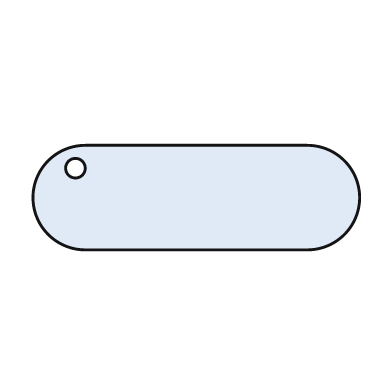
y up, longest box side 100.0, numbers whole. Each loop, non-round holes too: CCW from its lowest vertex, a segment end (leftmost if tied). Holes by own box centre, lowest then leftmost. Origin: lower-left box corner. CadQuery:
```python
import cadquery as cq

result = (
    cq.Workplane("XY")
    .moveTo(16.0, 0.0)
    .lineTo(84.0, 0.0)
    .threePointArc((100.0, 16.0), (84.0, 32.0))
    .lineTo(16.0, 32.0)
    .threePointArc((0.0, 16.0), (16.0, 0.0))
    .close()
    .moveTo(13.0, 25.0)
    .circle(3.0)
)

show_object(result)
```